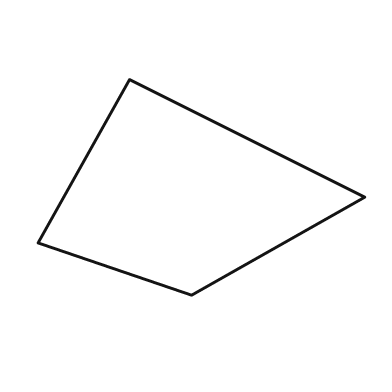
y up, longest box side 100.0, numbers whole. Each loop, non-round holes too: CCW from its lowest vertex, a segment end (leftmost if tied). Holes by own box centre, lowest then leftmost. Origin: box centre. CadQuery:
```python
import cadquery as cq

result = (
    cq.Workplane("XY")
    .moveTo(-3.0, -33.0)
    .lineTo(50.0, -3.0)
    .lineTo(-22.0, 33.0)
    .lineTo(-50.0, -17.0)
    .close()
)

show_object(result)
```